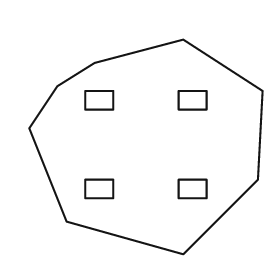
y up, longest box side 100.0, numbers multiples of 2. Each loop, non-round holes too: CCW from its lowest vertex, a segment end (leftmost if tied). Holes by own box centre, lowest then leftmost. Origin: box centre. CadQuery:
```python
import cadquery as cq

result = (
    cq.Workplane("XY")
    .moveTo(16.0, -46.0)
    .lineTo(48.0, -14.0)
    .lineTo(50.0, 24.0)
    .lineTo(16.0, 46.0)
    .lineTo(-22.0, 36.0)
    .lineTo(-38.0, 26.0)
    .lineTo(-50.0, 8.0)
    .lineTo(-34.0, -32.0)
    .close()
    .moveTo(-26.0, -22.0)
    .lineTo(-14.0, -22.0)
    .lineTo(-14.0, -14.0)
    .lineTo(-26.0, -14.0)
    .close()
    .moveTo(14.0, -22.0)
    .lineTo(26.0, -22.0)
    .lineTo(26.0, -14.0)
    .lineTo(14.0, -14.0)
    .close()
    .moveTo(-26.0, 16.0)
    .lineTo(-14.0, 16.0)
    .lineTo(-14.0, 24.0)
    .lineTo(-26.0, 24.0)
    .close()
    .moveTo(14.0, 16.0)
    .lineTo(26.0, 16.0)
    .lineTo(26.0, 24.0)
    .lineTo(14.0, 24.0)
    .close()
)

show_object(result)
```